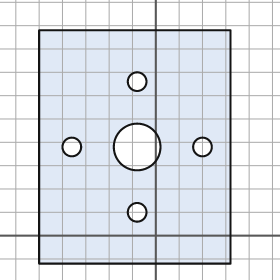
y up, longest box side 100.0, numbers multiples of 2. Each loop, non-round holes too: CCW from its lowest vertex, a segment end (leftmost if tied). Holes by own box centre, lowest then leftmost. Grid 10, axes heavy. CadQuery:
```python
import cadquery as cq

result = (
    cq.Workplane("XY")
    .moveTo(-50.0, -12.0)
    .lineTo(32.0, -12.0)
    .lineTo(32.0, 88.0)
    .lineTo(-50.0, 88.0)
    .close()
    .moveTo(-8.0, 10.0)
    .circle(4.0)
    .moveTo(-36.0, 38.0)
    .circle(4.0)
    .moveTo(-8.0, 38.0)
    .circle(10.0)
    .moveTo(20.0, 38.0)
    .circle(4.0)
    .moveTo(-8.0, 66.0)
    .circle(4.0)
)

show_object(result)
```